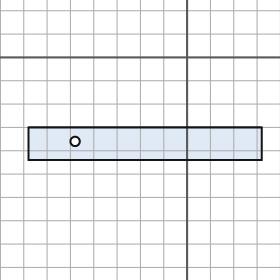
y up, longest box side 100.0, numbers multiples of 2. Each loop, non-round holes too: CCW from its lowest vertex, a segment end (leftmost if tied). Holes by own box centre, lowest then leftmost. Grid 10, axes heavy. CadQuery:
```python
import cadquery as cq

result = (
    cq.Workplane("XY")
    .moveTo(-68.0, -44.0)
    .lineTo(32.0, -44.0)
    .lineTo(32.0, -30.0)
    .lineTo(-68.0, -30.0)
    .close()
    .moveTo(-48.0, -36.0)
    .circle(2.0)
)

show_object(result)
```